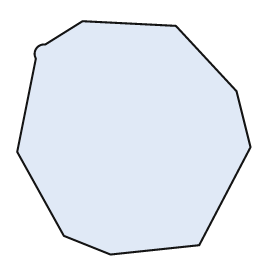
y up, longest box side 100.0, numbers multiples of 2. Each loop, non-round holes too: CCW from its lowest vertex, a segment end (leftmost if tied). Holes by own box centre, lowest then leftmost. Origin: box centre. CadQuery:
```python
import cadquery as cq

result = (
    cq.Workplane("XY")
    .moveTo(-10.0, -50.0)
    .lineTo(28.0, -46.0)
    .lineTo(50.0, -4.0)
    .lineTo(44.0, 20.0)
    .lineTo(18.0, 48.0)
    .lineTo(-22.0, 50.0)
    .lineTo(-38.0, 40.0)
    .threePointArc((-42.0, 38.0), (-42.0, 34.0))
    .lineTo(-50.0, -6.0)
    .lineTo(-30.0, -42.0)
    .close()
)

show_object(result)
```